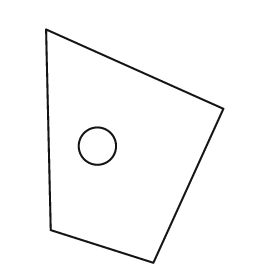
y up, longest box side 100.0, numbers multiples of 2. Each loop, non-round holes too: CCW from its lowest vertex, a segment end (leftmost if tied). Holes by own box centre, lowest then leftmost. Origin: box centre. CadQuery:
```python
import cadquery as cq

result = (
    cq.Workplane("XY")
    .moveTo(8.0, -50.0)
    .lineTo(38.0, 16.0)
    .lineTo(-38.0, 50.0)
    .lineTo(-36.0, -36.0)
    .close()
    .moveTo(-16.0, 0.0)
    .circle(8.0)
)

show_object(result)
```